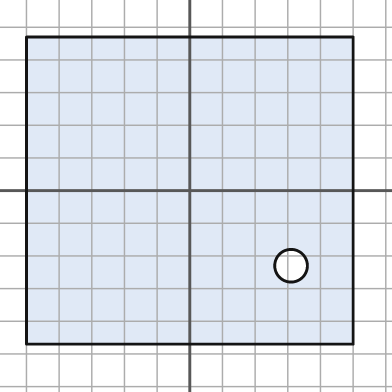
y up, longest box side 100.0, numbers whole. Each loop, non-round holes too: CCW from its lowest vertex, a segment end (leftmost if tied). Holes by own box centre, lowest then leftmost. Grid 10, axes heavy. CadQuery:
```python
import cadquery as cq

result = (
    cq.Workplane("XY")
    .moveTo(-50.0, -47.0)
    .lineTo(50.0, -47.0)
    .lineTo(50.0, 47.0)
    .lineTo(-50.0, 47.0)
    .close()
    .moveTo(31.0, -23.0)
    .circle(5.0)
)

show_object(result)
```